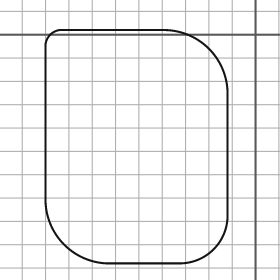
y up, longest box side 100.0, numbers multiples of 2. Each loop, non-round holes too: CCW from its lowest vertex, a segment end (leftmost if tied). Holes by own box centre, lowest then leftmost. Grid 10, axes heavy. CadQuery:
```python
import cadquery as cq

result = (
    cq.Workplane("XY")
    .moveTo(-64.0, -98.0)
    .lineTo(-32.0, -98.0)
    .threePointArc((-18.0, -92.0), (-12.0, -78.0))
    .lineTo(-12.0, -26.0)
    .threePointArc((-20.0, -6.0), (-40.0, 2.0))
    .lineTo(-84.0, 2.0)
    .threePointArc((-88.0, 0.0), (-90.0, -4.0))
    .lineTo(-90.0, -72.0)
    .threePointArc((-82.0, -90.0), (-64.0, -98.0))
    .close()
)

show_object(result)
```